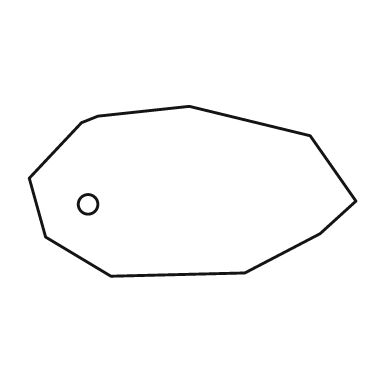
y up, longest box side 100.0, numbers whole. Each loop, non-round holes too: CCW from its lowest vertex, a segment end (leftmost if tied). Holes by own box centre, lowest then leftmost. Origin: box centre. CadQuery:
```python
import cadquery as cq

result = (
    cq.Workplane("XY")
    .moveTo(-25.0, -26.0)
    .lineTo(16.0, -25.0)
    .lineTo(39.0, -13.0)
    .lineTo(50.0, -3.0)
    .lineTo(36.0, 17.0)
    .lineTo(-1.0, 26.0)
    .lineTo(-29.0, 23.0)
    .lineTo(-34.0, 21.0)
    .lineTo(-50.0, 4.0)
    .lineTo(-45.0, -14.0)
    .close()
    .moveTo(-32.0, -4.0)
    .circle(3.0)
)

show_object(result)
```